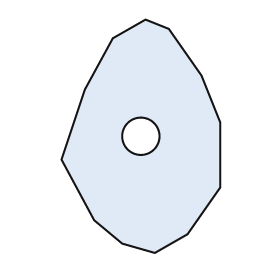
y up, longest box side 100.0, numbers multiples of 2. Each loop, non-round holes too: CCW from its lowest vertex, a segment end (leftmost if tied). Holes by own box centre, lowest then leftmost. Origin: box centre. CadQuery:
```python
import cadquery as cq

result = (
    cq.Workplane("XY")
    .moveTo(6.0, -50.0)
    .lineTo(20.0, -42.0)
    .lineTo(34.0, -22.0)
    .lineTo(34.0, 6.0)
    .lineTo(26.0, 26.0)
    .lineTo(12.0, 46.0)
    .lineTo(2.0, 50.0)
    .lineTo(-12.0, 42.0)
    .lineTo(-24.0, 20.0)
    .lineTo(-34.0, -10.0)
    .lineTo(-20.0, -36.0)
    .lineTo(-8.0, -46.0)
    .close()
    .moveTo(0.0, 0.0)
    .circle(8.0)
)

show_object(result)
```